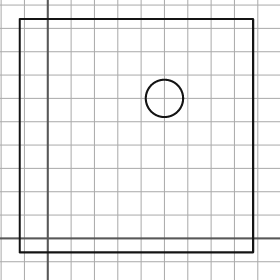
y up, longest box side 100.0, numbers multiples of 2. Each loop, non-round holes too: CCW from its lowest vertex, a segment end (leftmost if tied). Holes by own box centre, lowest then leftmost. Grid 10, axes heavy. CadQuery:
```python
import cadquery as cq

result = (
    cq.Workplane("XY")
    .moveTo(-12.0, -6.0)
    .lineTo(88.0, -6.0)
    .lineTo(88.0, 94.0)
    .lineTo(-12.0, 94.0)
    .close()
    .moveTo(50.0, 60.0)
    .circle(8.0)
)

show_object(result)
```